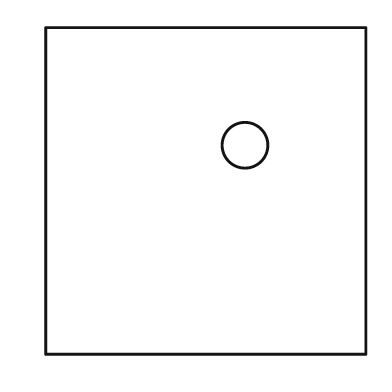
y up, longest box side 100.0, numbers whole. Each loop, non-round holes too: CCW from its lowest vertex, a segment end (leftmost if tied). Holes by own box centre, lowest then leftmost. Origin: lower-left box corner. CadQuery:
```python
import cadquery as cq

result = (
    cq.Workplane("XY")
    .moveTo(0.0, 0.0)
    .lineTo(98.0, 0.0)
    .lineTo(98.0, 100.0)
    .lineTo(0.0, 100.0)
    .close()
    .moveTo(61.0, 64.0)
    .circle(7.0)
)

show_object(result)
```